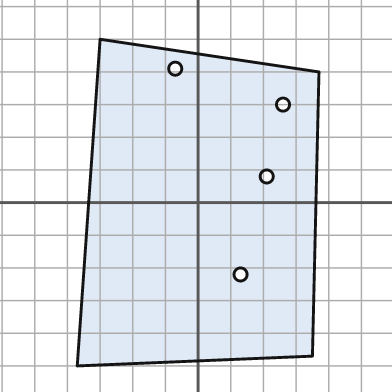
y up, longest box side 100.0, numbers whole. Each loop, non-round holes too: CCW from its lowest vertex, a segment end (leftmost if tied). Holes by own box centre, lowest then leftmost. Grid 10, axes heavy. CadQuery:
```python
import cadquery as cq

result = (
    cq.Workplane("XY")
    .moveTo(-37.0, -50.0)
    .lineTo(35.0, -47.0)
    .lineTo(37.0, 40.0)
    .lineTo(-30.0, 50.0)
    .close()
    .moveTo(13.0, -22.0)
    .circle(2.0)
    .moveTo(21.0, 8.0)
    .circle(2.0)
    .moveTo(26.0, 30.0)
    .circle(2.0)
    .moveTo(-7.0, 41.0)
    .circle(2.0)
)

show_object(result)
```